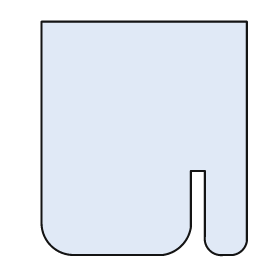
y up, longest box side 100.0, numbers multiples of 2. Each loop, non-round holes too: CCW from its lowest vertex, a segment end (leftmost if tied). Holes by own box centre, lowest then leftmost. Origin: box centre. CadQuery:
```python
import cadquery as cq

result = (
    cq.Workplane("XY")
    .moveTo(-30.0, -50.0)
    .lineTo(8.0, -50.0)
    .threePointArc((16.0, -46.0), (20.0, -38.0))
    .lineTo(20.0, -14.0)
    .lineTo(26.0, -14.0)
    .lineTo(26.0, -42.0)
    .threePointArc((28.0, -48.0), (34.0, -50.0))
    .lineTo(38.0, -50.0)
    .threePointArc((42.0, -48.0), (44.0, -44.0))
    .lineTo(44.0, 50.0)
    .lineTo(-44.0, 50.0)
    .lineTo(-44.0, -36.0)
    .threePointArc((-40.0, -46.0), (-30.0, -50.0))
    .close()
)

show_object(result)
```